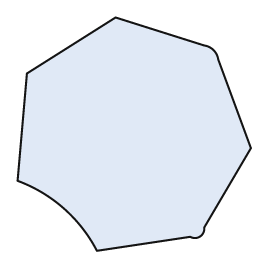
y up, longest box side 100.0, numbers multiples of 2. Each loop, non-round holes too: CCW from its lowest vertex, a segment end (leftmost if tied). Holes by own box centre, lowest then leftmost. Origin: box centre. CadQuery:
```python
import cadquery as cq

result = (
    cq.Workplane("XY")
    .moveTo(-16.0, -50.0)
    .lineTo(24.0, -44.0)
    .threePointArc((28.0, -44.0), (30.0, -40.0))
    .lineTo(50.0, -6.0)
    .lineTo(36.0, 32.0)
    .threePointArc((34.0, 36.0), (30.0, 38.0))
    .lineTo(-8.0, 50.0)
    .lineTo(-46.0, 26.0)
    .lineTo(-50.0, -20.0)
    .threePointArc((-30.0, -32.0), (-16.0, -50.0))
    .close()
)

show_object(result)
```